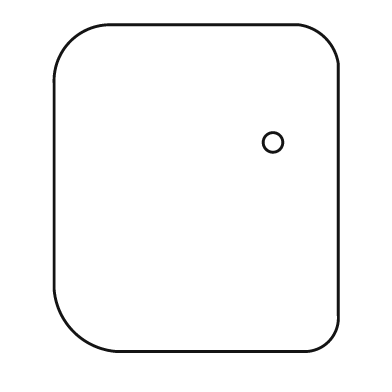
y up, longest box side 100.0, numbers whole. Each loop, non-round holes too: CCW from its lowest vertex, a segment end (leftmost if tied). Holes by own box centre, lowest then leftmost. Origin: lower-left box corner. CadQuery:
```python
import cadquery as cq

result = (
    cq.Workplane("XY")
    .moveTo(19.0, 0.0)
    .lineTo(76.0, 0.0)
    .threePointArc((84.0, 3.0), (87.0, 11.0))
    .lineTo(87.0, 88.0)
    .threePointArc((83.0, 96.0), (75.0, 100.0))
    .lineTo(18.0, 100.0)
    .threePointArc((5.0, 95.0), (0.0, 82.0))
    .lineTo(0.0, 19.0)
    .threePointArc((6.0, 6.0), (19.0, 0.0))
    .close()
    .moveTo(67.0, 64.0)
    .circle(3.0)
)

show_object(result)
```